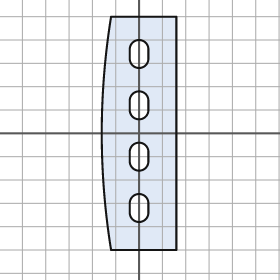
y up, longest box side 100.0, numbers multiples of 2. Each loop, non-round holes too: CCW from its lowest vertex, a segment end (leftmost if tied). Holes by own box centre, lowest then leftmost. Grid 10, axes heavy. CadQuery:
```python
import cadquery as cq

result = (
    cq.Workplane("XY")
    .moveTo(-12.0, -50.0)
    .lineTo(16.0, -50.0)
    .lineTo(16.0, 50.0)
    .lineTo(-12.0, 50.0)
    .threePointArc((-16.0, 0.0), (-12.0, -50.0))
    .close()
    .moveTo(-4.0, -34.0)
    .threePointArc((0.0, -38.0), (4.0, -34.0))
    .lineTo(4.0, -30.0)
    .threePointArc((0.0, -26.0), (-4.0, -30.0))
    .close()
    .moveTo(-4.0, -12.0)
    .threePointArc((0.0, -16.0), (4.0, -12.0))
    .lineTo(4.0, -8.0)
    .threePointArc((0.0, -4.0), (-4.0, -8.0))
    .close()
    .moveTo(-4.0, 10.0)
    .threePointArc((0.0, 6.0), (4.0, 10.0))
    .lineTo(4.0, 14.0)
    .threePointArc((0.0, 18.0), (-4.0, 14.0))
    .close()
    .moveTo(-4.0, 32.0)
    .threePointArc((0.0, 28.0), (4.0, 32.0))
    .lineTo(4.0, 36.0)
    .threePointArc((0.0, 40.0), (-4.0, 36.0))
    .close()
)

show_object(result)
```